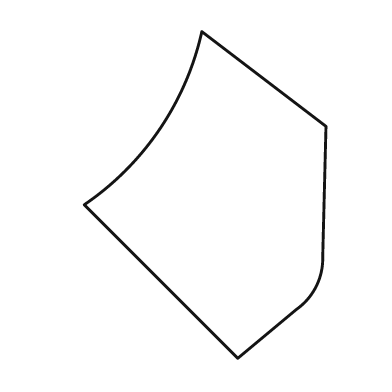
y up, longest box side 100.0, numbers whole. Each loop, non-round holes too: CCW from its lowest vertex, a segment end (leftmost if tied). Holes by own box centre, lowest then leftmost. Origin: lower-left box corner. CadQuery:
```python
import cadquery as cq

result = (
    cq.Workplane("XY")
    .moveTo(47.0, 0.0)
    .lineTo(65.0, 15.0)
    .threePointArc((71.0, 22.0), (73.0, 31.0))
    .lineTo(74.0, 71.0)
    .lineTo(36.0, 100.0)
    .threePointArc((23.0, 70.0), (0.0, 47.0))
    .close()
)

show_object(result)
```